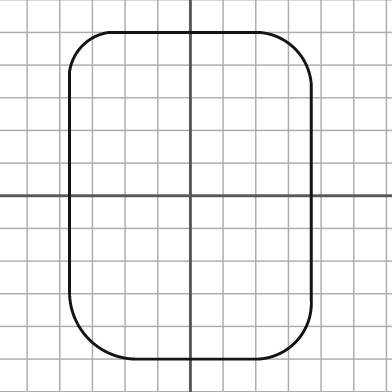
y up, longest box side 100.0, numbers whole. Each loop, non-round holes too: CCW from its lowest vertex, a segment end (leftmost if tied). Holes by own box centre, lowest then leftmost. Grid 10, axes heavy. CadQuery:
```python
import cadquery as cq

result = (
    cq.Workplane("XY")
    .moveTo(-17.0, -50.0)
    .lineTo(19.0, -50.0)
    .threePointArc((32.0, -45.0), (37.0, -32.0))
    .lineTo(37.0, 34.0)
    .threePointArc((32.0, 45.0), (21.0, 50.0))
    .lineTo(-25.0, 50.0)
    .threePointArc((-33.0, 46.0), (-37.0, 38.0))
    .lineTo(-37.0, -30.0)
    .threePointArc((-31.0, -44.0), (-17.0, -50.0))
    .close()
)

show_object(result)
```